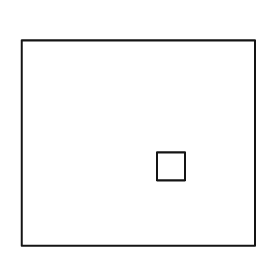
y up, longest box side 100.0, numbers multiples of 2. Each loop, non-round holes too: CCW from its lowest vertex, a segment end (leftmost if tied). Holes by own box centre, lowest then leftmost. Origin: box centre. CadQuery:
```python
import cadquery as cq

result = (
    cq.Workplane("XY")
    .moveTo(-50.0, -44.0)
    .lineTo(50.0, -44.0)
    .lineTo(50.0, 44.0)
    .lineTo(-50.0, 44.0)
    .close()
    .moveTo(8.0, -16.0)
    .lineTo(20.0, -16.0)
    .lineTo(20.0, -4.0)
    .lineTo(8.0, -4.0)
    .close()
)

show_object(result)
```